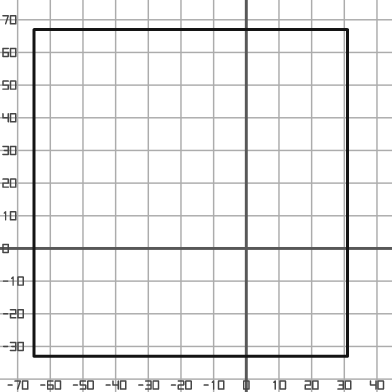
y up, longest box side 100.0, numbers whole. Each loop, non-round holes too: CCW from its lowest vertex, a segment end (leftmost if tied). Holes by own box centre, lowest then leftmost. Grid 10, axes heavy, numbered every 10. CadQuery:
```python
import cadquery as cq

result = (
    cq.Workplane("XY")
    .moveTo(-65.0, -33.0)
    .lineTo(31.0, -33.0)
    .lineTo(31.0, 67.0)
    .lineTo(-65.0, 67.0)
    .close()
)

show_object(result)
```